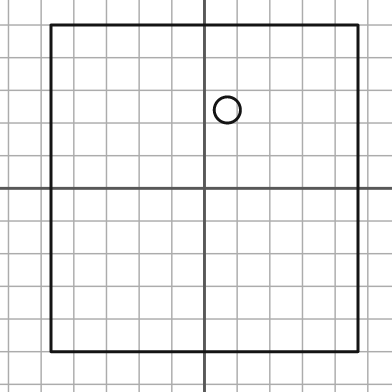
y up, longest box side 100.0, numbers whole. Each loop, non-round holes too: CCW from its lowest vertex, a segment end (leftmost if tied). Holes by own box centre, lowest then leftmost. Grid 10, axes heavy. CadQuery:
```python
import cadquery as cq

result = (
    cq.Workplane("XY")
    .moveTo(-47.0, -50.0)
    .lineTo(47.0, -50.0)
    .lineTo(47.0, 50.0)
    .lineTo(-47.0, 50.0)
    .close()
    .moveTo(7.0, 24.0)
    .circle(4.0)
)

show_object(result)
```